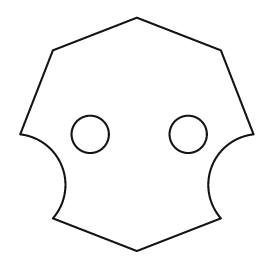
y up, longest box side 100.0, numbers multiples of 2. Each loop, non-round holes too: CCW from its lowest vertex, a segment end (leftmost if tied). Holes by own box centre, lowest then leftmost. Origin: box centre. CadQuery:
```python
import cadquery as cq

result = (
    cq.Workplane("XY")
    .moveTo(0.0, -50.0)
    .lineTo(36.0, -36.0)
    .threePointArc((32.0, -14.0), (50.0, 0.0))
    .lineTo(36.0, 36.0)
    .lineTo(0.0, 50.0)
    .lineTo(-36.0, 36.0)
    .lineTo(-50.0, 0.0)
    .threePointArc((-32.0, -14.0), (-36.0, -36.0))
    .close()
    .moveTo(-20.0, 0.0)
    .circle(8.0)
    .moveTo(22.0, 0.0)
    .circle(8.0)
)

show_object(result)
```